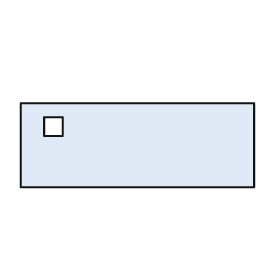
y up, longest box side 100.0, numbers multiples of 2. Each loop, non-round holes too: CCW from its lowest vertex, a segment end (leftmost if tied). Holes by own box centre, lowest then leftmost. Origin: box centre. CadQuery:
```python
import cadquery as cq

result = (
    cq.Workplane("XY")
    .moveTo(-50.0, -18.0)
    .lineTo(50.0, -18.0)
    .lineTo(50.0, 18.0)
    .lineTo(-50.0, 18.0)
    .close()
    .moveTo(-40.0, 4.0)
    .lineTo(-32.0, 4.0)
    .lineTo(-32.0, 12.0)
    .lineTo(-40.0, 12.0)
    .close()
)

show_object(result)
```